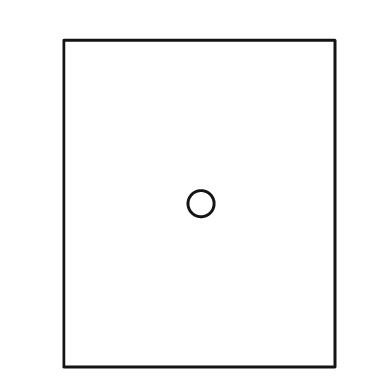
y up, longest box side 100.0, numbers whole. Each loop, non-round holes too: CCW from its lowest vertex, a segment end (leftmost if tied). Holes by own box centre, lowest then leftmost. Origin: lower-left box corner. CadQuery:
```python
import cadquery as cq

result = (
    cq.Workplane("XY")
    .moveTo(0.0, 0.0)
    .lineTo(83.0, 0.0)
    .lineTo(83.0, 100.0)
    .lineTo(0.0, 100.0)
    .close()
    .moveTo(42.0, 50.0)
    .circle(4.0)
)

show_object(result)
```